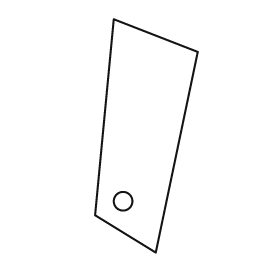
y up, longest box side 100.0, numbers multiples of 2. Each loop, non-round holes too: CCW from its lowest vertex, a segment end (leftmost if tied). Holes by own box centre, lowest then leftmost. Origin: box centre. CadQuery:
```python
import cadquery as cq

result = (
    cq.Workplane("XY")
    .moveTo(4.0, -50.0)
    .lineTo(22.0, 36.0)
    .lineTo(-14.0, 50.0)
    .lineTo(-22.0, -34.0)
    .close()
    .moveTo(-10.0, -28.0)
    .circle(4.0)
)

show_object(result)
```